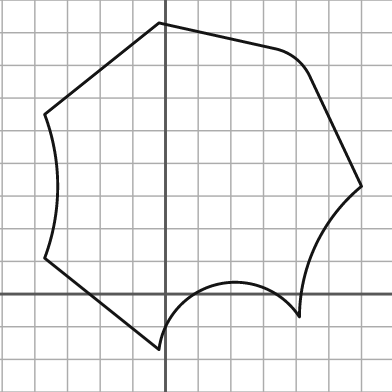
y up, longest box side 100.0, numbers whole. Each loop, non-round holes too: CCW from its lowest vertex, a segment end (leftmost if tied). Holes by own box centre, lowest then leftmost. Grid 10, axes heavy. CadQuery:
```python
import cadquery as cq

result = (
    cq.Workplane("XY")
    .moveTo(-2.0, -17.0)
    .threePointArc((16.0, 3.0), (41.0, -7.0))
    .threePointArc((46.0, 15.0), (60.0, 33.0))
    .lineTo(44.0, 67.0)
    .threePointArc((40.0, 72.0), (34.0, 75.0))
    .lineTo(-2.0, 83.0)
    .lineTo(-37.0, 55.0)
    .threePointArc((-33.0, 33.0), (-37.0, 11.0))
    .close()
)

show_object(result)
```